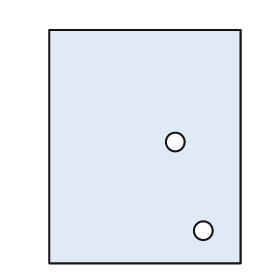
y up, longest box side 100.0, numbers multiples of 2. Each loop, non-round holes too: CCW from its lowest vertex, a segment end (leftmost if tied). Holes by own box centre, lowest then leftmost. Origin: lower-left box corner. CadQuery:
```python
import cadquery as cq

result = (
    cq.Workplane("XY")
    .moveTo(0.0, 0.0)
    .lineTo(82.0, 0.0)
    .lineTo(82.0, 100.0)
    .lineTo(0.0, 100.0)
    .close()
    .moveTo(66.0, 14.0)
    .circle(4.0)
    .moveTo(54.0, 52.0)
    .circle(4.0)
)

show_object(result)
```